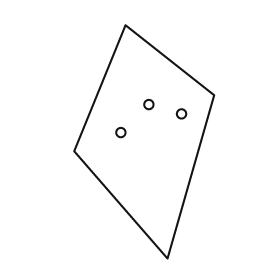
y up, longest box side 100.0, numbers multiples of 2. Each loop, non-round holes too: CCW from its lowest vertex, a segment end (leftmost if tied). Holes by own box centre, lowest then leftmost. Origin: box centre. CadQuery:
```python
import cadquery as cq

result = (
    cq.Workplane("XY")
    .moveTo(10.0, -50.0)
    .lineTo(30.0, 20.0)
    .lineTo(-8.0, 50.0)
    .lineTo(-30.0, -4.0)
    .close()
    .moveTo(-10.0, 4.0)
    .circle(2.0)
    .moveTo(16.0, 12.0)
    .circle(2.0)
    .moveTo(2.0, 16.0)
    .circle(2.0)
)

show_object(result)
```